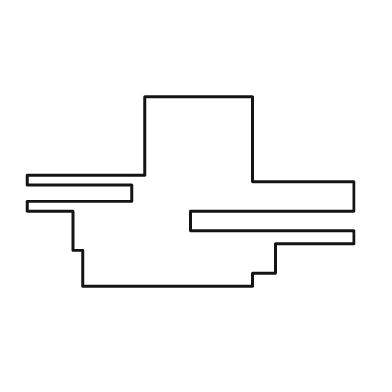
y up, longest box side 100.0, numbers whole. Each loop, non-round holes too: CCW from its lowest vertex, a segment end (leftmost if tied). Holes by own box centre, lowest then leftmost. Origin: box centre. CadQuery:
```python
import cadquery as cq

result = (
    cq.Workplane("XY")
    .moveTo(-33.0, -29.0)
    .lineTo(19.0, -29.0)
    .lineTo(19.0, -25.0)
    .lineTo(26.0, -25.0)
    .lineTo(26.0, -16.0)
    .lineTo(50.0, -16.0)
    .lineTo(50.0, -12.0)
    .lineTo(0.0, -12.0)
    .lineTo(0.0, -6.0)
    .lineTo(50.0, -6.0)
    .lineTo(50.0, 3.0)
    .lineTo(19.0, 3.0)
    .lineTo(19.0, 29.0)
    .lineTo(-14.0, 29.0)
    .lineTo(-14.0, 5.0)
    .lineTo(-50.0, 5.0)
    .lineTo(-50.0, 2.0)
    .lineTo(-18.0, 2.0)
    .lineTo(-18.0, -3.0)
    .lineTo(-50.0, -3.0)
    .lineTo(-50.0, -6.0)
    .lineTo(-36.0, -6.0)
    .lineTo(-36.0, -18.0)
    .lineTo(-33.0, -18.0)
    .close()
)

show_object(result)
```